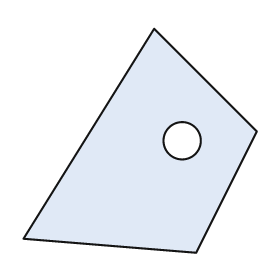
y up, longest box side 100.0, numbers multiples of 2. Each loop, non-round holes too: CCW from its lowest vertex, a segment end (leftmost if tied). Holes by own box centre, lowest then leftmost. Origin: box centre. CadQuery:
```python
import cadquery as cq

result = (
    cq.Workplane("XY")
    .moveTo(24.0, -48.0)
    .lineTo(50.0, 4.0)
    .lineTo(6.0, 48.0)
    .lineTo(-50.0, -42.0)
    .close()
    .moveTo(18.0, 0.0)
    .circle(8.0)
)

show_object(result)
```